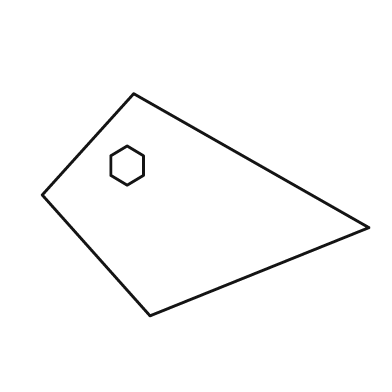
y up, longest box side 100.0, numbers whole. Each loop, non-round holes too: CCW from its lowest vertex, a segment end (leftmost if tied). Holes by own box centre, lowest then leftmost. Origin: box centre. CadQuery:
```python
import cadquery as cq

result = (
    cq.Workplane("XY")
    .moveTo(-17.0, -34.0)
    .lineTo(50.0, -7.0)
    .lineTo(-22.0, 34.0)
    .lineTo(-50.0, 3.0)
    .close()
    .moveTo(-24.0, 6.0)
    .lineTo(-19.0, 9.0)
    .lineTo(-19.0, 15.0)
    .lineTo(-24.0, 18.0)
    .lineTo(-29.0, 15.0)
    .lineTo(-29.0, 9.0)
    .close()
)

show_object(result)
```